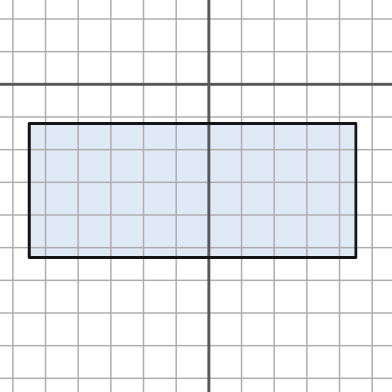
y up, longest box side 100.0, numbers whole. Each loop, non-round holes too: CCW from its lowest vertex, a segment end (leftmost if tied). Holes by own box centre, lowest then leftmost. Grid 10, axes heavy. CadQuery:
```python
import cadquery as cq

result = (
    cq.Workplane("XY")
    .moveTo(-55.0, -53.0)
    .lineTo(45.0, -53.0)
    .lineTo(45.0, -12.0)
    .lineTo(-55.0, -12.0)
    .close()
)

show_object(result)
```